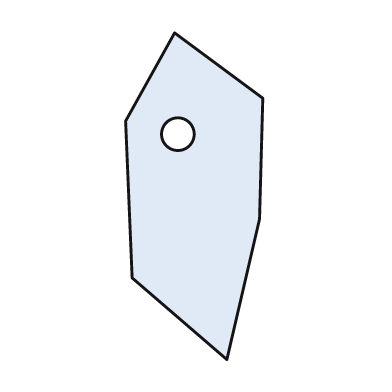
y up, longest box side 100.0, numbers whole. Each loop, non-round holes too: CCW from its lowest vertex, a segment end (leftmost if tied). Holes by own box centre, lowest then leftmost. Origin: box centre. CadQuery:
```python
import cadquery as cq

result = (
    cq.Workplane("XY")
    .moveTo(10.0, -50.0)
    .lineTo(20.0, -7.0)
    .lineTo(21.0, 30.0)
    .lineTo(-6.0, 50.0)
    .lineTo(-21.0, 23.0)
    .lineTo(-19.0, -25.0)
    .close()
    .moveTo(-5.0, 19.0)
    .circle(5.0)
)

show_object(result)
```